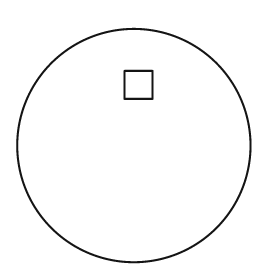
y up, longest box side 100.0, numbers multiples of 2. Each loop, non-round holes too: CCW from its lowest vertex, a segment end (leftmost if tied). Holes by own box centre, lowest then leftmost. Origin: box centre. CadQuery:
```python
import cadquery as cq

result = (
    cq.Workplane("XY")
    .moveTo(0.0, 0.0)
    .circle(50.0)
    .moveTo(-4.0, 20.0)
    .lineTo(8.0, 20.0)
    .lineTo(8.0, 32.0)
    .lineTo(-4.0, 32.0)
    .close()
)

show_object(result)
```